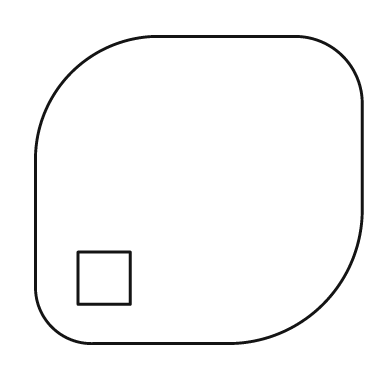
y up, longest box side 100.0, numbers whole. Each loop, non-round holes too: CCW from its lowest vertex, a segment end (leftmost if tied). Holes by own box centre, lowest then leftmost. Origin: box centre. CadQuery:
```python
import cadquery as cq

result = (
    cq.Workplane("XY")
    .moveTo(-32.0, -47.0)
    .lineTo(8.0, -47.0)
    .threePointArc((38.0, -35.0), (50.0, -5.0))
    .lineTo(50.0, 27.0)
    .threePointArc((44.0, 41.0), (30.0, 47.0))
    .lineTo(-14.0, 47.0)
    .threePointArc((-39.0, 36.0), (-50.0, 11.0))
    .lineTo(-50.0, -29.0)
    .threePointArc((-45.0, -42.0), (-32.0, -47.0))
    .close()
    .moveTo(-37.0, -35.0)
    .lineTo(-21.0, -35.0)
    .lineTo(-21.0, -19.0)
    .lineTo(-37.0, -19.0)
    .close()
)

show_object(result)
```